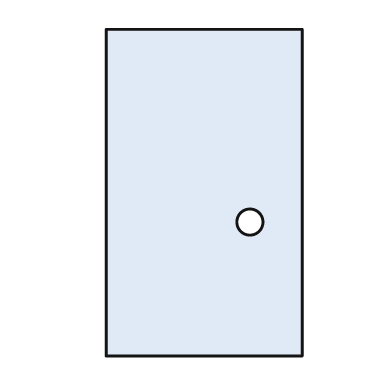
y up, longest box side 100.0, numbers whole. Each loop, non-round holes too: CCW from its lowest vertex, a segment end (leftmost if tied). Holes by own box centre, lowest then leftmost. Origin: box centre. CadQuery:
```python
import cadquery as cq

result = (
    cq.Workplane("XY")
    .moveTo(-30.0, -50.0)
    .lineTo(30.0, -50.0)
    .lineTo(30.0, 50.0)
    .lineTo(-30.0, 50.0)
    .close()
    .moveTo(14.0, -9.0)
    .circle(4.0)
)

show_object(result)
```